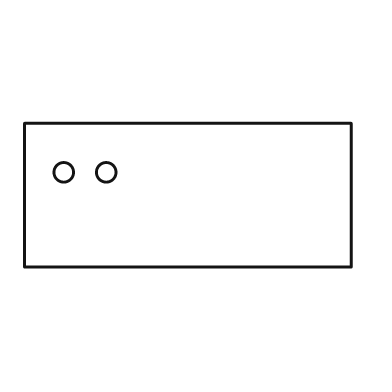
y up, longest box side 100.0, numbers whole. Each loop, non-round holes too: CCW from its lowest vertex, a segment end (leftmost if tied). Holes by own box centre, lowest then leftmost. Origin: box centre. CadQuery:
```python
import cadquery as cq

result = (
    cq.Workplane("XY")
    .moveTo(-50.0, -22.0)
    .lineTo(50.0, -22.0)
    .lineTo(50.0, 22.0)
    .lineTo(-50.0, 22.0)
    .close()
    .moveTo(-38.0, 7.0)
    .circle(3.0)
    .moveTo(-25.0, 7.0)
    .circle(3.0)
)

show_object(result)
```